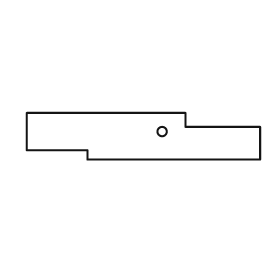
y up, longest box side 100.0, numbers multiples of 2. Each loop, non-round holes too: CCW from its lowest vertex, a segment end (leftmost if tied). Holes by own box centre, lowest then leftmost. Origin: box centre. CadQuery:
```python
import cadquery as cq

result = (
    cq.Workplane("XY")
    .moveTo(-24.0, -10.0)
    .lineTo(50.0, -10.0)
    .lineTo(50.0, 4.0)
    .lineTo(18.0, 4.0)
    .lineTo(18.0, 10.0)
    .lineTo(-50.0, 10.0)
    .lineTo(-50.0, -6.0)
    .lineTo(-24.0, -6.0)
    .close()
    .moveTo(8.0, 2.0)
    .circle(2.0)
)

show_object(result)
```